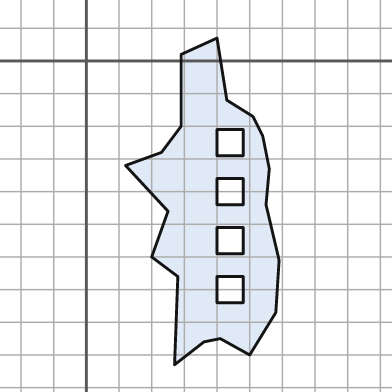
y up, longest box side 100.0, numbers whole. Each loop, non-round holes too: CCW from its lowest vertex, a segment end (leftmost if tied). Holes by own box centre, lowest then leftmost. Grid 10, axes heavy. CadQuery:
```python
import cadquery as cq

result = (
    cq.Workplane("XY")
    .moveTo(27.0, -93.0)
    .lineTo(36.0, -86.0)
    .lineTo(41.0, -85.0)
    .lineTo(50.0, -90.0)
    .lineTo(58.0, -77.0)
    .lineTo(59.0, -61.0)
    .lineTo(55.0, -44.0)
    .lineTo(56.0, -33.0)
    .lineTo(54.0, -23.0)
    .lineTo(51.0, -17.0)
    .lineTo(43.0, -12.0)
    .lineTo(40.0, 7.0)
    .lineTo(29.0, 2.0)
    .lineTo(29.0, -20.0)
    .lineTo(23.0, -28.0)
    .lineTo(12.0, -32.0)
    .lineTo(25.0, -46.0)
    .lineTo(20.0, -60.0)
    .lineTo(28.0, -66.0)
    .close()
    .moveTo(40.0, -74.0)
    .lineTo(48.0, -74.0)
    .lineTo(48.0, -66.0)
    .lineTo(40.0, -66.0)
    .close()
    .moveTo(40.0, -59.0)
    .lineTo(48.0, -59.0)
    .lineTo(48.0, -51.0)
    .lineTo(40.0, -51.0)
    .close()
    .moveTo(40.0, -44.0)
    .lineTo(48.0, -44.0)
    .lineTo(48.0, -36.0)
    .lineTo(40.0, -36.0)
    .close()
    .moveTo(40.0, -29.0)
    .lineTo(48.0, -29.0)
    .lineTo(48.0, -21.0)
    .lineTo(40.0, -21.0)
    .close()
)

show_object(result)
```